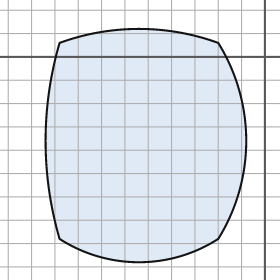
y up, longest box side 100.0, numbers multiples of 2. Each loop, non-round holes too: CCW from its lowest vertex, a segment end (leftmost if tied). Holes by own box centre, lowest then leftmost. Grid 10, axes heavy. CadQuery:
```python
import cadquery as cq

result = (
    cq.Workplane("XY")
    .moveTo(-88.0, -78.0)
    .threePointArc((-54.0, -88.0), (-20.0, -78.0))
    .threePointArc((-8.0, -36.0), (-20.0, 6.0))
    .threePointArc((-54.0, 12.0), (-88.0, 6.0))
    .threePointArc((-94.0, -36.0), (-88.0, -78.0))
    .close()
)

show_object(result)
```